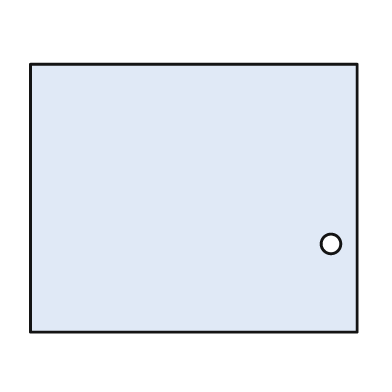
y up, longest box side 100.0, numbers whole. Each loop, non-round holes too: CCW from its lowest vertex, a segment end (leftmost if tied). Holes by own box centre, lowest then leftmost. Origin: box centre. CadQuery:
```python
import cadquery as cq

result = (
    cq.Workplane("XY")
    .moveTo(-50.0, -41.0)
    .lineTo(50.0, -41.0)
    .lineTo(50.0, 41.0)
    .lineTo(-50.0, 41.0)
    .close()
    .moveTo(42.0, -14.0)
    .circle(3.0)
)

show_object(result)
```